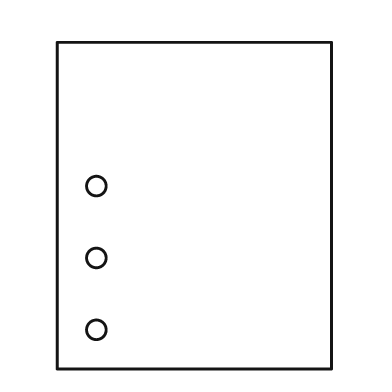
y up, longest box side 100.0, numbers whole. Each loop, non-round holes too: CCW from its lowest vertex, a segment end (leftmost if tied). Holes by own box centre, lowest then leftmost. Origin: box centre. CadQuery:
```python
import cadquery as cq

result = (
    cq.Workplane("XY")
    .moveTo(-42.0, -50.0)
    .lineTo(42.0, -50.0)
    .lineTo(42.0, 50.0)
    .lineTo(-42.0, 50.0)
    .close()
    .moveTo(-30.0, -38.0)
    .circle(3.0)
    .moveTo(-30.0, -16.0)
    .circle(3.0)
    .moveTo(-30.0, 6.0)
    .circle(3.0)
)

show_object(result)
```